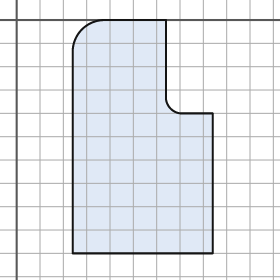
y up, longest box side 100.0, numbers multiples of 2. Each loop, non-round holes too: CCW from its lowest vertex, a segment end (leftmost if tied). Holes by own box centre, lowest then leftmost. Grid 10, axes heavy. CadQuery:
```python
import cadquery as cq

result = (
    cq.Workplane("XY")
    .moveTo(24.0, -100.0)
    .lineTo(84.0, -100.0)
    .lineTo(84.0, -40.0)
    .lineTo(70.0, -40.0)
    .threePointArc((66.0, -38.0), (64.0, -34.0))
    .lineTo(64.0, 0.0)
    .lineTo(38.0, 0.0)
    .threePointArc((28.0, -4.0), (24.0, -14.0))
    .close()
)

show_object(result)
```